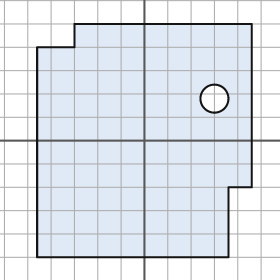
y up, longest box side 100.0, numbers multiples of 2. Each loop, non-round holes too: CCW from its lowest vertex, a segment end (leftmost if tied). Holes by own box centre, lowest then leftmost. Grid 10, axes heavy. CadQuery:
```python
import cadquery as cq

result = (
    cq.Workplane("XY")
    .moveTo(-46.0, -50.0)
    .lineTo(36.0, -50.0)
    .lineTo(36.0, -20.0)
    .lineTo(46.0, -20.0)
    .lineTo(46.0, 50.0)
    .lineTo(-30.0, 50.0)
    .lineTo(-30.0, 40.0)
    .lineTo(-46.0, 40.0)
    .close()
    .moveTo(30.0, 18.0)
    .circle(6.0)
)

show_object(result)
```